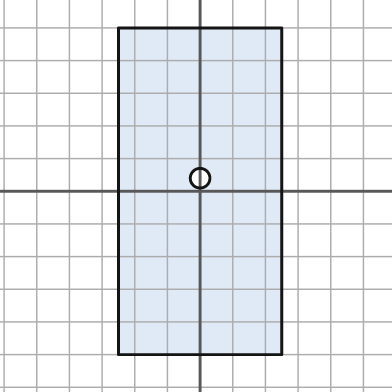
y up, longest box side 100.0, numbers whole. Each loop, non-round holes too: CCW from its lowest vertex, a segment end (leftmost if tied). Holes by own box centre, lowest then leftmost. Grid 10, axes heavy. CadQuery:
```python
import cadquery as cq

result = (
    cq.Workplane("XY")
    .moveTo(-25.0, -50.0)
    .lineTo(25.0, -50.0)
    .lineTo(25.0, 50.0)
    .lineTo(-25.0, 50.0)
    .close()
    .moveTo(0.0, 4.0)
    .circle(3.0)
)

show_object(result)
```